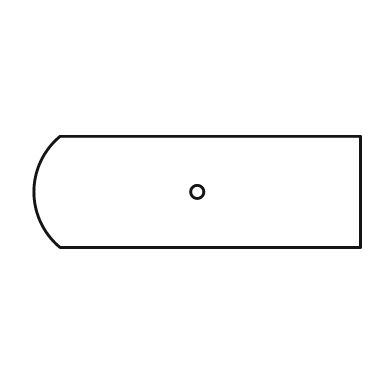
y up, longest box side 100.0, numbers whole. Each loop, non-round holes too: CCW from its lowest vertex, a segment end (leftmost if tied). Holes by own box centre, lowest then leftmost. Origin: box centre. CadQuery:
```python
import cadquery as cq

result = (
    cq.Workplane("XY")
    .moveTo(-42.0, -17.0)
    .lineTo(50.0, -17.0)
    .lineTo(50.0, 17.0)
    .lineTo(-42.0, 17.0)
    .threePointArc((-50.0, 0.0), (-42.0, -17.0))
    .close()
    .moveTo(0.0, 0.0)
    .circle(2.0)
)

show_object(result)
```